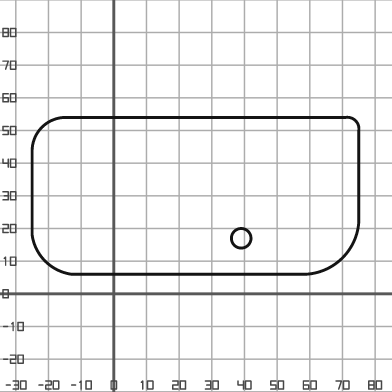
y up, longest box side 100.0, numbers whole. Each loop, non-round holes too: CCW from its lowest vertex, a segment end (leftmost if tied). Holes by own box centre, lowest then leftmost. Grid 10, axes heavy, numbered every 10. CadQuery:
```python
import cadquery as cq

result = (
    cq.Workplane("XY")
    .moveTo(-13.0, 6.0)
    .lineTo(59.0, 6.0)
    .threePointArc((70.0, 11.0), (75.0, 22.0))
    .lineTo(75.0, 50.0)
    .threePointArc((74.0, 53.0), (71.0, 54.0))
    .lineTo(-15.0, 54.0)
    .threePointArc((-22.0, 51.0), (-25.0, 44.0))
    .lineTo(-25.0, 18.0)
    .threePointArc((-21.0, 10.0), (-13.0, 6.0))
    .close()
    .moveTo(39.0, 17.0)
    .circle(3.0)
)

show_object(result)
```